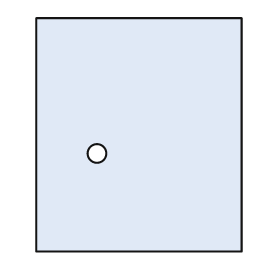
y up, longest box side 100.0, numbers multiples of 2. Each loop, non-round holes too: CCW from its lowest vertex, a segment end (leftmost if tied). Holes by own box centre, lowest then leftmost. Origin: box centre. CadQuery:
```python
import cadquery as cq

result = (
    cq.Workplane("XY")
    .moveTo(-44.0, -50.0)
    .lineTo(44.0, -50.0)
    .lineTo(44.0, 50.0)
    .lineTo(-44.0, 50.0)
    .close()
    .moveTo(-18.0, -8.0)
    .circle(4.0)
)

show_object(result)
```